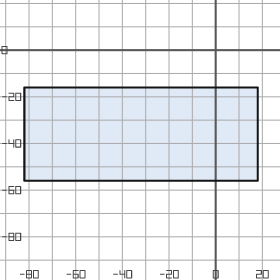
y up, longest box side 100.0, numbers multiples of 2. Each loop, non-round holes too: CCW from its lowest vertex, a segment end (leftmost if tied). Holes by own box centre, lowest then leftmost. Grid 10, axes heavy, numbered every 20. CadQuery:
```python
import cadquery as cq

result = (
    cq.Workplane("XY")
    .moveTo(-82.0, -56.0)
    .lineTo(18.0, -56.0)
    .lineTo(18.0, -16.0)
    .lineTo(-82.0, -16.0)
    .close()
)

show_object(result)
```